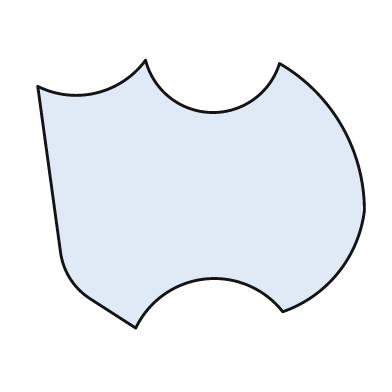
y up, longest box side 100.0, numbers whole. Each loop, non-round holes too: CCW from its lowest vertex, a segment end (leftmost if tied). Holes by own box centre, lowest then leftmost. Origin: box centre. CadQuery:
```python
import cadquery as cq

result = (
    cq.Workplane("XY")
    .moveTo(-20.0, -41.0)
    .threePointArc((1.0, -26.0), (25.0, -36.0))
    .threePointArc((42.0, -24.0), (50.0, -5.0))
    .threePointArc((43.0, 21.0), (24.0, 40.0))
    .threePointArc((3.0, 25.0), (-17.0, 41.0))
    .threePointArc((-32.0, 31.0), (-50.0, 33.0))
    .lineTo(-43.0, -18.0)
    .threePointArc((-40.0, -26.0), (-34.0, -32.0))
    .close()
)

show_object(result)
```